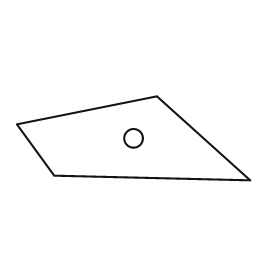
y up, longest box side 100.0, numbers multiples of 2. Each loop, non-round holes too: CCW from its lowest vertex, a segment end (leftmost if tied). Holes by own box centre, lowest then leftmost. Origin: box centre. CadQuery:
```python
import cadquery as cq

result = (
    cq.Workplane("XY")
    .moveTo(50.0, -18.0)
    .lineTo(10.0, 18.0)
    .lineTo(-50.0, 6.0)
    .lineTo(-34.0, -16.0)
    .close()
    .moveTo(0.0, 0.0)
    .circle(4.0)
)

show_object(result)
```